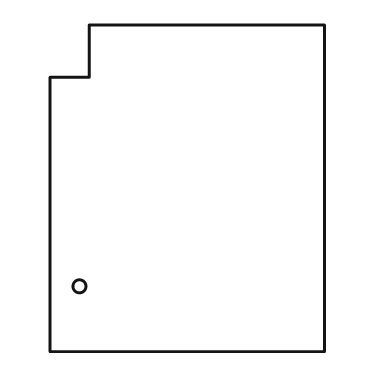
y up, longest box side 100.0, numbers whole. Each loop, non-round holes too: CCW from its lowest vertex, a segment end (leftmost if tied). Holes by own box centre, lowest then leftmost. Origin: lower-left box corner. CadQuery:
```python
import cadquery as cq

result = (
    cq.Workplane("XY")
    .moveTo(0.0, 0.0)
    .lineTo(84.0, 0.0)
    .lineTo(84.0, 100.0)
    .lineTo(12.0, 100.0)
    .lineTo(12.0, 84.0)
    .lineTo(0.0, 84.0)
    .close()
    .moveTo(9.0, 20.0)
    .circle(2.0)
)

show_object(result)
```